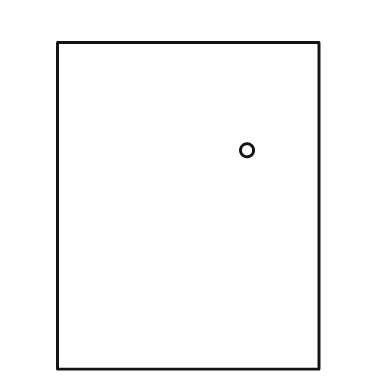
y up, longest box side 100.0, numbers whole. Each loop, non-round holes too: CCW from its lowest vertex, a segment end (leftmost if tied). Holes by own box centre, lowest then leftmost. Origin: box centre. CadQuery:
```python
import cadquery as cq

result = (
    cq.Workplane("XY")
    .moveTo(-40.0, -50.0)
    .lineTo(40.0, -50.0)
    .lineTo(40.0, 50.0)
    .lineTo(-40.0, 50.0)
    .close()
    .moveTo(18.0, 17.0)
    .circle(2.0)
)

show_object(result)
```